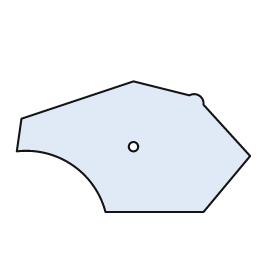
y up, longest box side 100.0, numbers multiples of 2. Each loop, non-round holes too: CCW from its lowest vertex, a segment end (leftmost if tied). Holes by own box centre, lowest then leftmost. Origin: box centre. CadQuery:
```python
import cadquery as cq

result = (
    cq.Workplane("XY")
    .moveTo(-12.0, -28.0)
    .lineTo(30.0, -28.0)
    .lineTo(50.0, -4.0)
    .lineTo(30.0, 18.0)
    .threePointArc((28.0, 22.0), (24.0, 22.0))
    .lineTo(0.0, 28.0)
    .lineTo(-48.0, 12.0)
    .lineTo(-50.0, -2.0)
    .threePointArc((-26.0, -8.0), (-12.0, -28.0))
    .close()
    .moveTo(0.0, 0.0)
    .circle(2.0)
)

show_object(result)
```